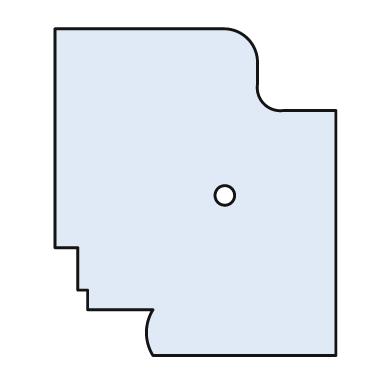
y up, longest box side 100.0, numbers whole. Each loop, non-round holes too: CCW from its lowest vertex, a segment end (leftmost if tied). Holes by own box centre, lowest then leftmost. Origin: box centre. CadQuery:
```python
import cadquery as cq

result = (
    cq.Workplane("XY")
    .moveTo(-13.0, -50.0)
    .lineTo(43.0, -50.0)
    .lineTo(43.0, 25.0)
    .lineTo(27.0, 25.0)
    .threePointArc((21.0, 27.0), (19.0, 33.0))
    .lineTo(19.0, 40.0)
    .threePointArc((16.0, 47.0), (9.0, 50.0))
    .lineTo(-43.0, 50.0)
    .lineTo(-43.0, -17.0)
    .lineTo(-36.0, -17.0)
    .lineTo(-36.0, -30.0)
    .lineTo(-33.0, -30.0)
    .lineTo(-33.0, -36.0)
    .lineTo(-13.0, -36.0)
    .threePointArc((-15.0, -43.0), (-13.0, -50.0))
    .close()
    .moveTo(9.0, -1.0)
    .circle(3.0)
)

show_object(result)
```